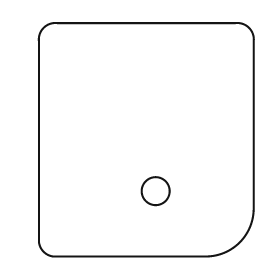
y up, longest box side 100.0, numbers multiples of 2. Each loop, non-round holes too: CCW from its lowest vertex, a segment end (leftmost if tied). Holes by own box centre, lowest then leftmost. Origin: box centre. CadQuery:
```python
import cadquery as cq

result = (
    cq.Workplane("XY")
    .moveTo(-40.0, -50.0)
    .lineTo(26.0, -50.0)
    .threePointArc((40.0, -44.0), (46.0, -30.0))
    .lineTo(46.0, 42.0)
    .threePointArc((44.0, 48.0), (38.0, 50.0))
    .lineTo(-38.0, 50.0)
    .threePointArc((-44.0, 48.0), (-46.0, 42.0))
    .lineTo(-46.0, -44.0)
    .threePointArc((-44.0, -48.0), (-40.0, -50.0))
    .close()
    .moveTo(4.0, -22.0)
    .circle(6.0)
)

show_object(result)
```